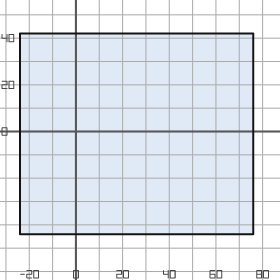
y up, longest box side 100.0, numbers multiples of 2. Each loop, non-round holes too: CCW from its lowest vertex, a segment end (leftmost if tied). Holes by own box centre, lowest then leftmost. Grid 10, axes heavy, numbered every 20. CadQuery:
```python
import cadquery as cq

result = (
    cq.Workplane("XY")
    .moveTo(-24.0, -44.0)
    .lineTo(76.0, -44.0)
    .lineTo(76.0, 42.0)
    .lineTo(-24.0, 42.0)
    .close()
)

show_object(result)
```